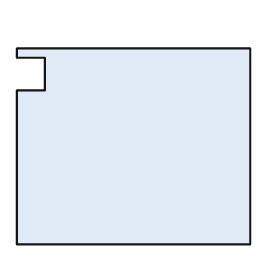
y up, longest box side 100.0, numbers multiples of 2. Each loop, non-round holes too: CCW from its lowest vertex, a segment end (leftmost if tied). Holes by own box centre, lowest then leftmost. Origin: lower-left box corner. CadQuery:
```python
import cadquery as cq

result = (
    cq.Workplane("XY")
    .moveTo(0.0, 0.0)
    .lineTo(100.0, 0.0)
    .lineTo(100.0, 84.0)
    .lineTo(0.0, 84.0)
    .lineTo(0.0, 80.0)
    .lineTo(12.0, 80.0)
    .lineTo(12.0, 66.0)
    .lineTo(0.0, 66.0)
    .close()
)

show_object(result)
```